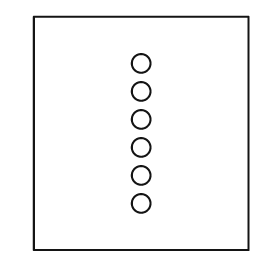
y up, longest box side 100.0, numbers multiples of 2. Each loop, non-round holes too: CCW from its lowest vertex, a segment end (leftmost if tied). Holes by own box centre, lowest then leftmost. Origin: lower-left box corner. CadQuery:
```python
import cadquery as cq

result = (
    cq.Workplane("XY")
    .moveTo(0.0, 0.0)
    .lineTo(92.0, 0.0)
    .lineTo(92.0, 100.0)
    .lineTo(0.0, 100.0)
    .close()
    .moveTo(46.0, 20.0)
    .circle(4.0)
    .moveTo(46.0, 32.0)
    .circle(4.0)
    .moveTo(46.0, 44.0)
    .circle(4.0)
    .moveTo(46.0, 56.0)
    .circle(4.0)
    .moveTo(46.0, 68.0)
    .circle(4.0)
    .moveTo(46.0, 80.0)
    .circle(4.0)
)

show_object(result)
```